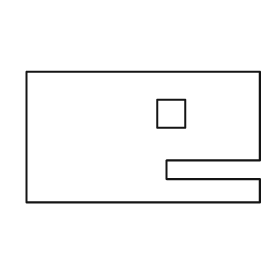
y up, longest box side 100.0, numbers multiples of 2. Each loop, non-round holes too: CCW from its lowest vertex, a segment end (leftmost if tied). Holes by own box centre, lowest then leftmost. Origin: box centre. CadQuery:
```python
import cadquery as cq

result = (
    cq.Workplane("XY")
    .moveTo(-50.0, -28.0)
    .lineTo(50.0, -28.0)
    .lineTo(50.0, -18.0)
    .lineTo(10.0, -18.0)
    .lineTo(10.0, -10.0)
    .lineTo(50.0, -10.0)
    .lineTo(50.0, 28.0)
    .lineTo(-50.0, 28.0)
    .close()
    .moveTo(6.0, 4.0)
    .lineTo(18.0, 4.0)
    .lineTo(18.0, 16.0)
    .lineTo(6.0, 16.0)
    .close()
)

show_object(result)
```